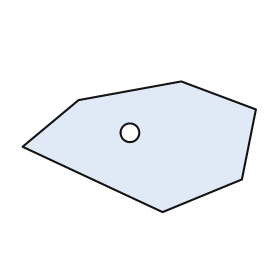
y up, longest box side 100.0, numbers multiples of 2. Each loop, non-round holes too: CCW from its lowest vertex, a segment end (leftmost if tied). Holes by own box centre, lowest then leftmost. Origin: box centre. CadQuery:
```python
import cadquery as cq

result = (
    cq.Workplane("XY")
    .moveTo(10.0, -28.0)
    .lineTo(44.0, -14.0)
    .lineTo(50.0, 16.0)
    .lineTo(18.0, 28.0)
    .lineTo(-26.0, 20.0)
    .lineTo(-50.0, 0.0)
    .close()
    .moveTo(-4.0, 6.0)
    .circle(4.0)
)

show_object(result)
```